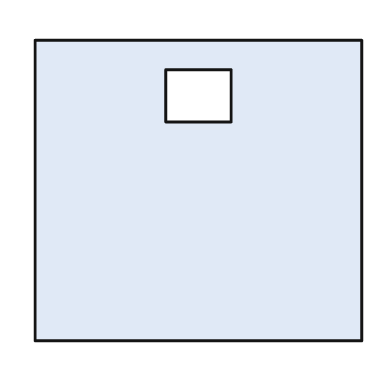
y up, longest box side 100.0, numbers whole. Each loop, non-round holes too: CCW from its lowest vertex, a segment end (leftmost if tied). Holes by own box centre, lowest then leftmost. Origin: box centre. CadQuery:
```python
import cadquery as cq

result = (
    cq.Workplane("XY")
    .moveTo(-50.0, -46.0)
    .lineTo(50.0, -46.0)
    .lineTo(50.0, 46.0)
    .lineTo(-50.0, 46.0)
    .close()
    .moveTo(-10.0, 21.0)
    .lineTo(10.0, 21.0)
    .lineTo(10.0, 37.0)
    .lineTo(-10.0, 37.0)
    .close()
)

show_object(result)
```